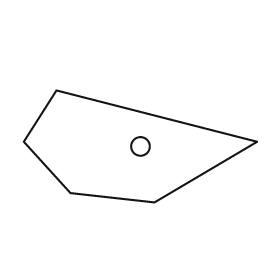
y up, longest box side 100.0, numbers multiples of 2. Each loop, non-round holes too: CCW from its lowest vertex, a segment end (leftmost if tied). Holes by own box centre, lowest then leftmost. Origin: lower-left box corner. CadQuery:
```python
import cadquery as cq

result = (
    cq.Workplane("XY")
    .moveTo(56.0, 0.0)
    .lineTo(100.0, 26.0)
    .lineTo(14.0, 48.0)
    .lineTo(0.0, 26.0)
    .lineTo(20.0, 4.0)
    .close()
    .moveTo(50.0, 24.0)
    .circle(4.0)
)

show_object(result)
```